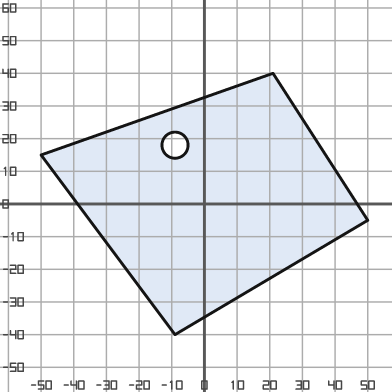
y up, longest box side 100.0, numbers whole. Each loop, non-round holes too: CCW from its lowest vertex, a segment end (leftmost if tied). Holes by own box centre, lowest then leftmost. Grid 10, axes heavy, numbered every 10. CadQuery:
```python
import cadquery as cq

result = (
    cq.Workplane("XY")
    .moveTo(-9.0, -40.0)
    .lineTo(50.0, -5.0)
    .lineTo(21.0, 40.0)
    .lineTo(-50.0, 15.0)
    .close()
    .moveTo(-9.0, 18.0)
    .circle(4.0)
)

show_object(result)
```